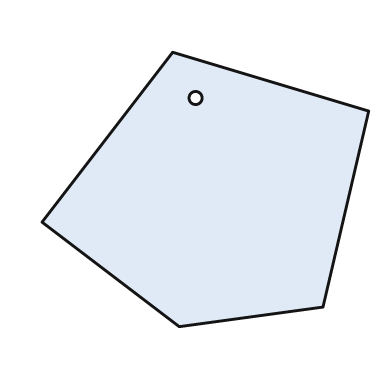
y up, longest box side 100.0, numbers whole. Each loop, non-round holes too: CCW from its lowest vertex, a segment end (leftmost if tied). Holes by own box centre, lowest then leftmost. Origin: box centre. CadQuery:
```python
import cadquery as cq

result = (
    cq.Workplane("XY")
    .moveTo(-8.0, -42.0)
    .lineTo(36.0, -36.0)
    .lineTo(50.0, 24.0)
    .lineTo(-10.0, 42.0)
    .lineTo(-50.0, -10.0)
    .close()
    .moveTo(-3.0, 28.0)
    .circle(2.0)
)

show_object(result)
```